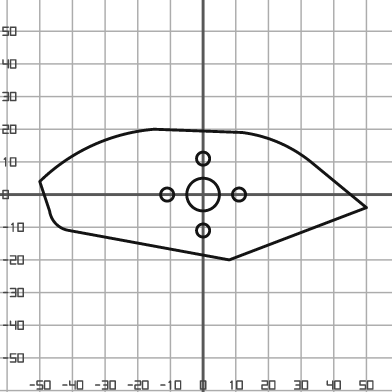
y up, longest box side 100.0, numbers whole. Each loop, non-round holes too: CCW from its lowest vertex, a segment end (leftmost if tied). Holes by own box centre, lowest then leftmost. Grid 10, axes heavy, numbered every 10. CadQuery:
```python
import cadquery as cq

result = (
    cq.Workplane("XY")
    .moveTo(8.0, -20.0)
    .lineTo(50.0, -4.0)
    .lineTo(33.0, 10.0)
    .threePointArc((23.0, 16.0), (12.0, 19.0))
    .lineTo(-15.0, 20.0)
    .threePointArc((-34.0, 15.0), (-50.0, 4.0))
    .lineTo(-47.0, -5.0)
    .threePointArc((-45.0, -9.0), (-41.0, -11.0))
    .close()
    .moveTo(0.0, -11.0)
    .circle(2.0)
    .moveTo(-11.0, 0.0)
    .circle(2.0)
    .moveTo(0.0, 0.0)
    .circle(5.0)
    .moveTo(11.0, 0.0)
    .circle(2.0)
    .moveTo(0.0, 11.0)
    .circle(2.0)
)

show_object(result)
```